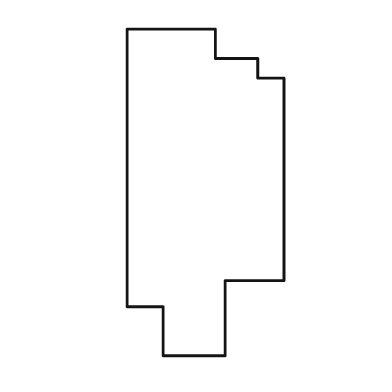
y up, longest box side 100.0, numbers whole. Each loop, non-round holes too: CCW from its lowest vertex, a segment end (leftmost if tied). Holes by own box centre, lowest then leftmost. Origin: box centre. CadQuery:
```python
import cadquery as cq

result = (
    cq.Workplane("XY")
    .moveTo(-13.0, -50.0)
    .lineTo(6.0, -50.0)
    .lineTo(6.0, -27.0)
    .lineTo(24.0, -27.0)
    .lineTo(24.0, 35.0)
    .lineTo(16.0, 35.0)
    .lineTo(16.0, 41.0)
    .lineTo(3.0, 41.0)
    .lineTo(3.0, 50.0)
    .lineTo(-24.0, 50.0)
    .lineTo(-24.0, -35.0)
    .lineTo(-13.0, -35.0)
    .close()
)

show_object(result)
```